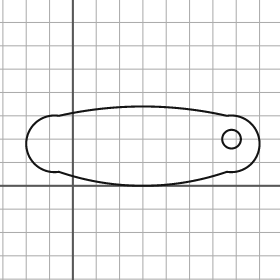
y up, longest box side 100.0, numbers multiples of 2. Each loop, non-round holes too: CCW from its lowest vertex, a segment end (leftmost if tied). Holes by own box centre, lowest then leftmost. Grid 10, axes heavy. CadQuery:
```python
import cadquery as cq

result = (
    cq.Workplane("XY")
    .moveTo(-6.0, 6.0)
    .threePointArc((30.0, 0.0), (66.0, 6.0))
    .threePointArc((80.0, 18.0), (66.0, 30.0))
    .threePointArc((30.0, 34.0), (-6.0, 30.0))
    .threePointArc((-20.0, 18.0), (-6.0, 6.0))
    .close()
    .moveTo(68.0, 20.0)
    .circle(4.0)
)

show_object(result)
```